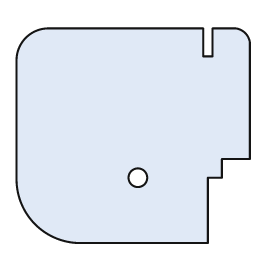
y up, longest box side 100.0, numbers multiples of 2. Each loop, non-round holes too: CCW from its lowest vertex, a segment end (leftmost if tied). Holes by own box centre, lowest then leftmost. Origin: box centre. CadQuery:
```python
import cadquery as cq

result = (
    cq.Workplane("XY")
    .moveTo(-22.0, -46.0)
    .lineTo(32.0, -46.0)
    .lineTo(32.0, -18.0)
    .lineTo(38.0, -18.0)
    .lineTo(38.0, -10.0)
    .lineTo(50.0, -10.0)
    .lineTo(50.0, 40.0)
    .threePointArc((48.0, 44.0), (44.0, 46.0))
    .lineTo(34.0, 46.0)
    .lineTo(34.0, 34.0)
    .lineTo(30.0, 34.0)
    .lineTo(30.0, 46.0)
    .lineTo(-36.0, 46.0)
    .threePointArc((-46.0, 42.0), (-50.0, 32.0))
    .lineTo(-50.0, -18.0)
    .threePointArc((-42.0, -38.0), (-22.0, -46.0))
    .close()
    .moveTo(2.0, -18.0)
    .circle(4.0)
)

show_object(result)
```